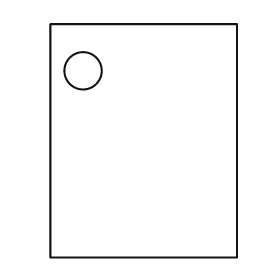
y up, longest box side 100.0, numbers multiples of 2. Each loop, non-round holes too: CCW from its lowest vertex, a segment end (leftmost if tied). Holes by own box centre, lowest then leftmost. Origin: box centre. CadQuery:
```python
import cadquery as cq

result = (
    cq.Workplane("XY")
    .moveTo(-40.0, -50.0)
    .lineTo(40.0, -50.0)
    .lineTo(40.0, 50.0)
    .lineTo(-40.0, 50.0)
    .close()
    .moveTo(-26.0, 30.0)
    .circle(8.0)
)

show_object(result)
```